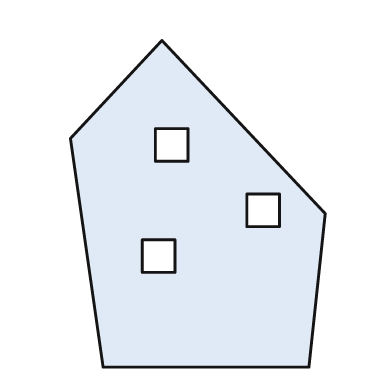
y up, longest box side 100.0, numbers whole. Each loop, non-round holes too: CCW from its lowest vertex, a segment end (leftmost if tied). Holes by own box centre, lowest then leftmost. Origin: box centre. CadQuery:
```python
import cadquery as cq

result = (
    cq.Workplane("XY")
    .moveTo(-29.0, -50.0)
    .lineTo(34.0, -50.0)
    .lineTo(39.0, -3.0)
    .lineTo(-11.0, 50.0)
    .lineTo(-39.0, 20.0)
    .close()
    .moveTo(-17.0, -21.0)
    .lineTo(-7.0, -21.0)
    .lineTo(-7.0, -11.0)
    .lineTo(-17.0, -11.0)
    .close()
    .moveTo(15.0, -7.0)
    .lineTo(25.0, -7.0)
    .lineTo(25.0, 3.0)
    .lineTo(15.0, 3.0)
    .close()
    .moveTo(-13.0, 13.0)
    .lineTo(-3.0, 13.0)
    .lineTo(-3.0, 23.0)
    .lineTo(-13.0, 23.0)
    .close()
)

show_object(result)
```